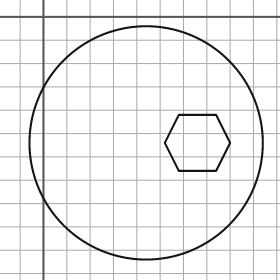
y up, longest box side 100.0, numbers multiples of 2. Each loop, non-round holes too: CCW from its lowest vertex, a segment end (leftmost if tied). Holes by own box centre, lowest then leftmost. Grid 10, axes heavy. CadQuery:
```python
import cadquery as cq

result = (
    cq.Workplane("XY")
    .moveTo(44.0, -54.0)
    .circle(50.0)
    .moveTo(58.0, -66.0)
    .lineTo(74.0, -66.0)
    .lineTo(80.0, -54.0)
    .lineTo(74.0, -42.0)
    .lineTo(58.0, -42.0)
    .lineTo(52.0, -54.0)
    .close()
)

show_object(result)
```